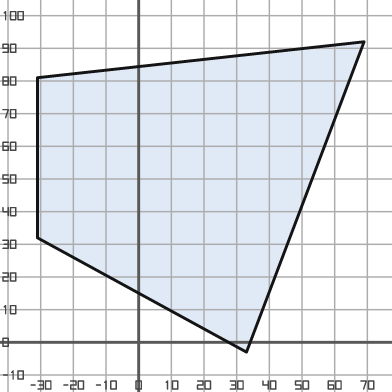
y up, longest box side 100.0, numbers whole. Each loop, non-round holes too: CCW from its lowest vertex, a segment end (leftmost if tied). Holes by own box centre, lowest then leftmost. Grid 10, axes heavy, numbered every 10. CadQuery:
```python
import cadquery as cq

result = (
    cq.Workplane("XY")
    .moveTo(33.0, -3.0)
    .lineTo(69.0, 92.0)
    .lineTo(-31.0, 81.0)
    .lineTo(-31.0, 32.0)
    .close()
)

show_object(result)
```